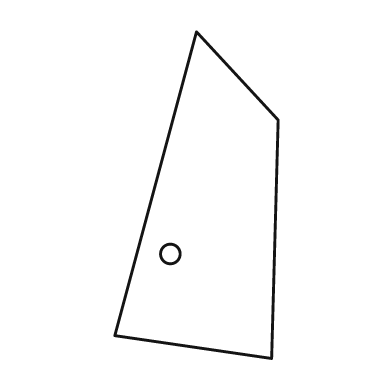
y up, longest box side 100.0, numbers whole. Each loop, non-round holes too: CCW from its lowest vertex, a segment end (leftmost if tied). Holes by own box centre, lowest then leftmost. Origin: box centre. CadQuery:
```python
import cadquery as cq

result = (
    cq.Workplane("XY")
    .moveTo(23.0, -50.0)
    .lineTo(25.0, 23.0)
    .lineTo(0.0, 50.0)
    .lineTo(-25.0, -43.0)
    .close()
    .moveTo(-8.0, -18.0)
    .circle(3.0)
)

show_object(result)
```